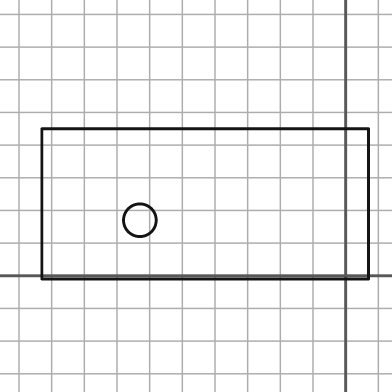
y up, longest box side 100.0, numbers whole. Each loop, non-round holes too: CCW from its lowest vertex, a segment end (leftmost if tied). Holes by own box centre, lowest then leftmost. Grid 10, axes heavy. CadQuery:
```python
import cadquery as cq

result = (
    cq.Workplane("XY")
    .moveTo(-93.0, -1.0)
    .lineTo(7.0, -1.0)
    .lineTo(7.0, 45.0)
    .lineTo(-93.0, 45.0)
    .close()
    .moveTo(-63.0, 17.0)
    .circle(5.0)
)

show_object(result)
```